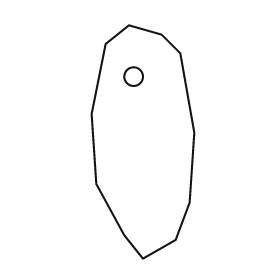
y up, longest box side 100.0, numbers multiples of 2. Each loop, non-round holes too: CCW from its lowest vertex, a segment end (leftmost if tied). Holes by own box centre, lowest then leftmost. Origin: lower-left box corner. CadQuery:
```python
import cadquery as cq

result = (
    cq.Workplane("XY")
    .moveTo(22.0, 0.0)
    .lineTo(36.0, 8.0)
    .lineTo(42.0, 24.0)
    .lineTo(44.0, 54.0)
    .lineTo(38.0, 88.0)
    .lineTo(30.0, 96.0)
    .lineTo(16.0, 100.0)
    .lineTo(6.0, 92.0)
    .lineTo(0.0, 62.0)
    .lineTo(2.0, 32.0)
    .lineTo(14.0, 10.0)
    .close()
    .moveTo(18.0, 78.0)
    .circle(4.0)
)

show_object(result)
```